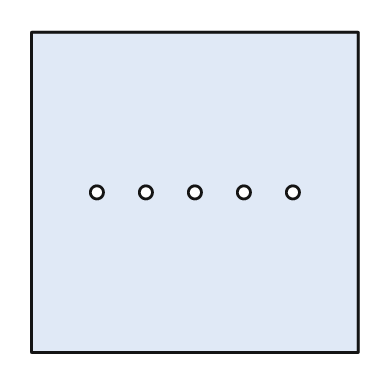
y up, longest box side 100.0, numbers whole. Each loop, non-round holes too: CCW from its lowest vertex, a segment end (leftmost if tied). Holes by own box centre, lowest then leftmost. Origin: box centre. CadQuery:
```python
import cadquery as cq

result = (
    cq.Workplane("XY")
    .moveTo(-50.0, -49.0)
    .lineTo(50.0, -49.0)
    .lineTo(50.0, 49.0)
    .lineTo(-50.0, 49.0)
    .close()
    .moveTo(-30.0, 0.0)
    .circle(2.0)
    .moveTo(-15.0, 0.0)
    .circle(2.0)
    .moveTo(0.0, 0.0)
    .circle(2.0)
    .moveTo(15.0, 0.0)
    .circle(2.0)
    .moveTo(30.0, 0.0)
    .circle(2.0)
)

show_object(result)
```